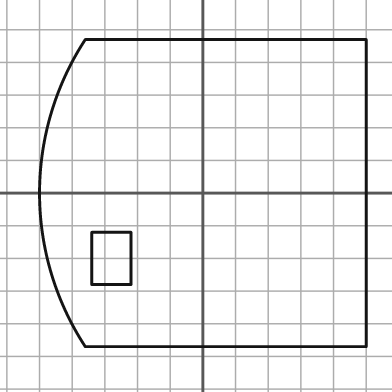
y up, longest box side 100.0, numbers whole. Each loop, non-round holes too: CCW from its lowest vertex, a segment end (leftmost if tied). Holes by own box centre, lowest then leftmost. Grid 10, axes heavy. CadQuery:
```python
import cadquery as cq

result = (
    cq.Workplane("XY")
    .moveTo(-36.0, -47.0)
    .lineTo(50.0, -47.0)
    .lineTo(50.0, 47.0)
    .lineTo(-36.0, 47.0)
    .threePointArc((-50.0, 0.0), (-36.0, -47.0))
    .close()
    .moveTo(-34.0, -28.0)
    .lineTo(-22.0, -28.0)
    .lineTo(-22.0, -12.0)
    .lineTo(-34.0, -12.0)
    .close()
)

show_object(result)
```